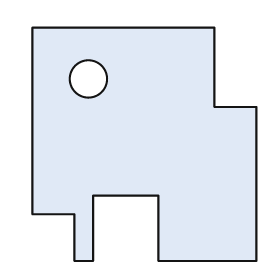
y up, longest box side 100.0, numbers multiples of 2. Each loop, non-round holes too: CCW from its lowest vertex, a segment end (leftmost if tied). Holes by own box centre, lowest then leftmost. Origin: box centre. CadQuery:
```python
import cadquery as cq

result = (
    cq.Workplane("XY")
    .moveTo(-30.0, -50.0)
    .lineTo(-22.0, -50.0)
    .lineTo(-22.0, -22.0)
    .lineTo(6.0, -22.0)
    .lineTo(6.0, -50.0)
    .lineTo(48.0, -50.0)
    .lineTo(48.0, 16.0)
    .lineTo(30.0, 16.0)
    .lineTo(30.0, 50.0)
    .lineTo(-48.0, 50.0)
    .lineTo(-48.0, -30.0)
    .lineTo(-30.0, -30.0)
    .close()
    .moveTo(-24.0, 28.0)
    .circle(8.0)
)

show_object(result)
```